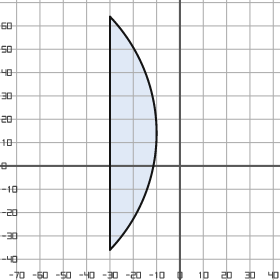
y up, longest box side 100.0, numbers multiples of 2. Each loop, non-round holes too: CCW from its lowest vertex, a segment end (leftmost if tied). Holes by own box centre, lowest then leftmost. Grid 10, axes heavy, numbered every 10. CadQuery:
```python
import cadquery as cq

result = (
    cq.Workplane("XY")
    .moveTo(-30.0, -36.0)
    .threePointArc((-10.0, 14.0), (-30.0, 64.0))
    .close()
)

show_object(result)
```